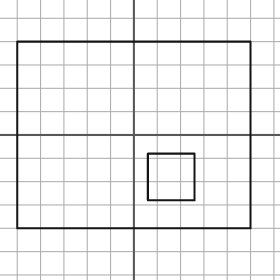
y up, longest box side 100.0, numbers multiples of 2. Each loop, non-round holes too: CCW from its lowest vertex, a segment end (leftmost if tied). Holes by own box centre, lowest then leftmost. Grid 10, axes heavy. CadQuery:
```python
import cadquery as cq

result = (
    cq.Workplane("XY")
    .moveTo(-50.0, -40.0)
    .lineTo(50.0, -40.0)
    .lineTo(50.0, 40.0)
    .lineTo(-50.0, 40.0)
    .close()
    .moveTo(6.0, -28.0)
    .lineTo(26.0, -28.0)
    .lineTo(26.0, -8.0)
    .lineTo(6.0, -8.0)
    .close()
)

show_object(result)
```